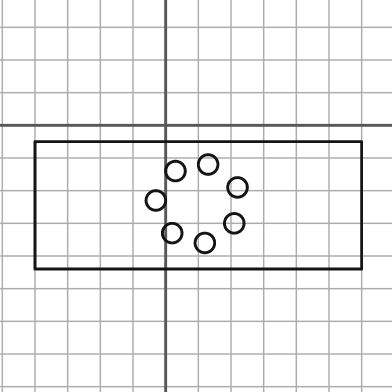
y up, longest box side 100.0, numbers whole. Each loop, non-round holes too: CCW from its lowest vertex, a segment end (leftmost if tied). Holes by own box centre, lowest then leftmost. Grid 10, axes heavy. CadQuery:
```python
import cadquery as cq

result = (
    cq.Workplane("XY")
    .moveTo(-40.0, -44.0)
    .lineTo(60.0, -44.0)
    .lineTo(60.0, -5.0)
    .lineTo(-40.0, -5.0)
    .close()
    .moveTo(12.0, -36.0)
    .circle(3.0)
    .moveTo(2.0, -33.0)
    .circle(3.0)
    .moveTo(21.0, -30.0)
    .circle(3.0)
    .moveTo(-3.0, -23.0)
    .circle(3.0)
    .moveTo(22.0, -19.0)
    .circle(3.0)
    .moveTo(3.0, -14.0)
    .circle(3.0)
    .moveTo(13.0, -12.0)
    .circle(3.0)
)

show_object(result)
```